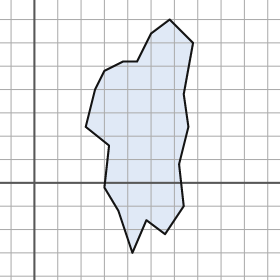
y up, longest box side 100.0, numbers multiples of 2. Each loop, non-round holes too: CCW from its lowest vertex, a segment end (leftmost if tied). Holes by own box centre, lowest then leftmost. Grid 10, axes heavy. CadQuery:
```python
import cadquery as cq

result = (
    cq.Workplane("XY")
    .moveTo(42.0, -30.0)
    .lineTo(48.0, -16.0)
    .lineTo(56.0, -22.0)
    .lineTo(64.0, -10.0)
    .lineTo(62.0, 8.0)
    .lineTo(66.0, 24.0)
    .lineTo(64.0, 38.0)
    .lineTo(68.0, 60.0)
    .lineTo(58.0, 70.0)
    .lineTo(50.0, 64.0)
    .lineTo(44.0, 52.0)
    .lineTo(38.0, 52.0)
    .lineTo(30.0, 48.0)
    .lineTo(26.0, 40.0)
    .lineTo(22.0, 24.0)
    .lineTo(32.0, 16.0)
    .lineTo(30.0, -2.0)
    .lineTo(36.0, -12.0)
    .close()
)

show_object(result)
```